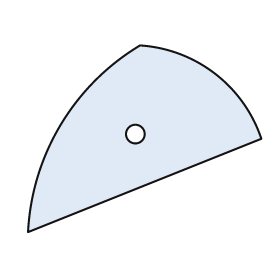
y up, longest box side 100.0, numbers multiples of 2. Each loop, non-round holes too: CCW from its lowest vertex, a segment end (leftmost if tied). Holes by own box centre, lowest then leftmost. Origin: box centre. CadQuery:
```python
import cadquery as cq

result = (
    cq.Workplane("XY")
    .moveTo(-50.0, -40.0)
    .lineTo(50.0, 0.0)
    .threePointArc((30.0, 28.0), (-2.0, 40.0))
    .threePointArc((-36.0, 6.0), (-50.0, -40.0))
    .close()
    .moveTo(-4.0, 2.0)
    .circle(4.0)
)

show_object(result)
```